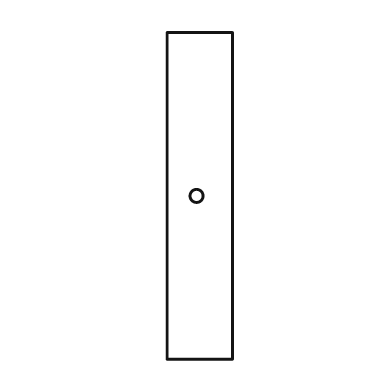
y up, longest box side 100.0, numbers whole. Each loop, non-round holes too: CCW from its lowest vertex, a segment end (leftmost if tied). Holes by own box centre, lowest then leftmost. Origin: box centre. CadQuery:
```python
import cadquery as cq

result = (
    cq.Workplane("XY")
    .moveTo(-10.0, -50.0)
    .lineTo(10.0, -50.0)
    .lineTo(10.0, 50.0)
    .lineTo(-10.0, 50.0)
    .close()
    .moveTo(-1.0, 0.0)
    .circle(2.0)
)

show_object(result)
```